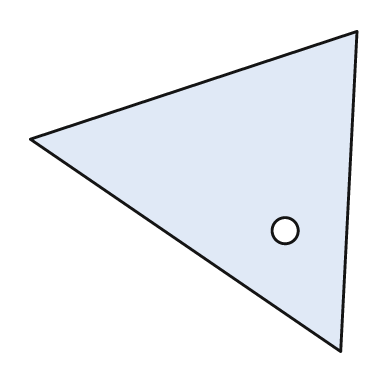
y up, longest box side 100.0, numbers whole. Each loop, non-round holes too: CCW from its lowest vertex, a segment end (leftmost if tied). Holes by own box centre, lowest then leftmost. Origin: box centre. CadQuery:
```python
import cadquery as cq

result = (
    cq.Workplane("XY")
    .moveTo(45.0, -49.0)
    .lineTo(50.0, 49.0)
    .lineTo(-50.0, 16.0)
    .close()
    .moveTo(28.0, -12.0)
    .circle(4.0)
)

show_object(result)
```